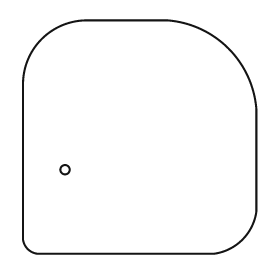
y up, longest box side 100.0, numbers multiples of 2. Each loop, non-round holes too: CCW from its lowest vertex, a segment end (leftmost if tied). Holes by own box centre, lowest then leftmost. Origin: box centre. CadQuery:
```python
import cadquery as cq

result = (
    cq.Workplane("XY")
    .moveTo(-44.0, -50.0)
    .lineTo(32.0, -50.0)
    .threePointArc((44.0, -44.0), (50.0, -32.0))
    .lineTo(50.0, 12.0)
    .threePointArc((38.0, 38.0), (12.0, 50.0))
    .lineTo(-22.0, 50.0)
    .threePointArc((-42.0, 42.0), (-50.0, 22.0))
    .lineTo(-50.0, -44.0)
    .threePointArc((-48.0, -48.0), (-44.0, -50.0))
    .close()
    .moveTo(-32.0, -14.0)
    .circle(2.0)
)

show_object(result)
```